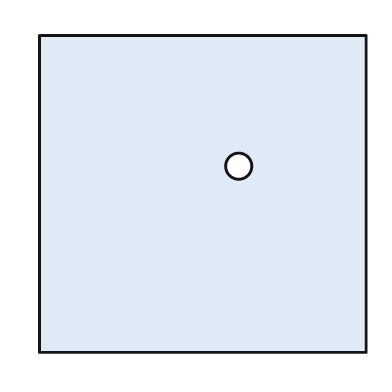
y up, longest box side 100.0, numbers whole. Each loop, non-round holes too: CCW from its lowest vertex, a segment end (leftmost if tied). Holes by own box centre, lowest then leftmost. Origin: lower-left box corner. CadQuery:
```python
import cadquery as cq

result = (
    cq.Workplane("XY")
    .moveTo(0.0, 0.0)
    .lineTo(100.0, 0.0)
    .lineTo(100.0, 97.0)
    .lineTo(0.0, 97.0)
    .close()
    .moveTo(61.0, 57.0)
    .circle(4.0)
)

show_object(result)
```